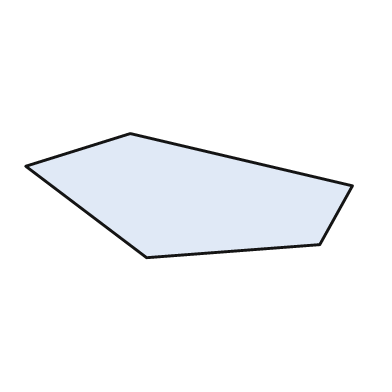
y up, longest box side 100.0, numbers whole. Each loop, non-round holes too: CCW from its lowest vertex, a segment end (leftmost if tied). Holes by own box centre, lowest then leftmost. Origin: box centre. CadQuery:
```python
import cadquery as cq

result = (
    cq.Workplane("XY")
    .moveTo(-13.0, -19.0)
    .lineTo(40.0, -15.0)
    .lineTo(50.0, 3.0)
    .lineTo(-18.0, 19.0)
    .lineTo(-50.0, 9.0)
    .close()
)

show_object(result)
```